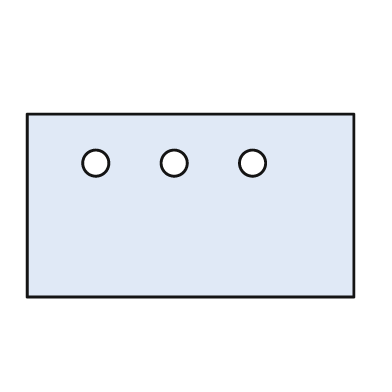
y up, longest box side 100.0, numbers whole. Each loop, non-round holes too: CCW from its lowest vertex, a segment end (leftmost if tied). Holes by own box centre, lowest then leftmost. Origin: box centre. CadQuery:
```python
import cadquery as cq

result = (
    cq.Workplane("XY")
    .moveTo(-50.0, -28.0)
    .lineTo(50.0, -28.0)
    .lineTo(50.0, 28.0)
    .lineTo(-50.0, 28.0)
    .close()
    .moveTo(-29.0, 13.0)
    .circle(4.0)
    .moveTo(-5.0, 13.0)
    .circle(4.0)
    .moveTo(19.0, 13.0)
    .circle(4.0)
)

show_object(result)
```